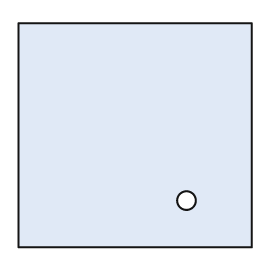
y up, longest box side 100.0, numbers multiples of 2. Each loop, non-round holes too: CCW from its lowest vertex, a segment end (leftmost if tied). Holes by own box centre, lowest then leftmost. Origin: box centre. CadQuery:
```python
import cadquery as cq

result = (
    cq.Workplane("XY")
    .moveTo(-50.0, -48.0)
    .lineTo(50.0, -48.0)
    .lineTo(50.0, 48.0)
    .lineTo(-50.0, 48.0)
    .close()
    .moveTo(22.0, -28.0)
    .circle(4.0)
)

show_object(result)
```